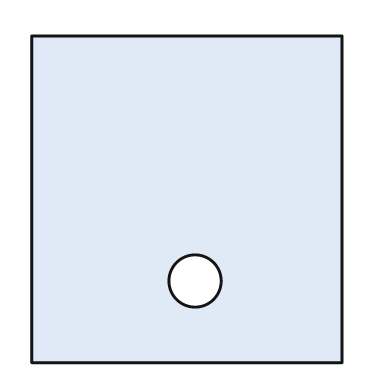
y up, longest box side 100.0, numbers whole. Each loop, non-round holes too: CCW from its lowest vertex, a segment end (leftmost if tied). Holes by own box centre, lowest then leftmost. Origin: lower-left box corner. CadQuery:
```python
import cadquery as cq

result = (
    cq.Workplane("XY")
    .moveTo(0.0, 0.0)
    .lineTo(95.0, 0.0)
    .lineTo(95.0, 100.0)
    .lineTo(0.0, 100.0)
    .close()
    .moveTo(50.0, 25.0)
    .circle(8.0)
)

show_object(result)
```